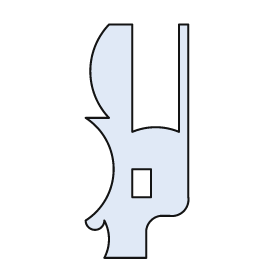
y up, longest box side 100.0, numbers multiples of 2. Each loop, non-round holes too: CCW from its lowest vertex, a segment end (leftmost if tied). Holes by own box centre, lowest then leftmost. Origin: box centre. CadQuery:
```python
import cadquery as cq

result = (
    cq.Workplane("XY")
    .moveTo(-14.0, -50.0)
    .lineTo(4.0, -50.0)
    .lineTo(4.0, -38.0)
    .threePointArc((6.0, -34.0), (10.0, -32.0))
    .lineTo(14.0, -32.0)
    .threePointArc((20.0, -30.0), (22.0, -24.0))
    .lineTo(22.0, 50.0)
    .lineTo(18.0, 50.0)
    .lineTo(18.0, 4.0)
    .threePointArc((8.0, 6.0), (-2.0, 4.0))
    .lineTo(-2.0, 50.0)
    .lineTo(-12.0, 50.0)
    .threePointArc((-20.0, 30.0), (-12.0, 10.0))
    .lineTo(-22.0, 10.0)
    .threePointArc((-10.0, -12.0), (-22.0, -34.0))
    .threePointArc((-18.0, -38.0), (-14.0, -34.0))
    .threePointArc((-12.0, -42.0), (-14.0, -50.0))
    .close()
    .moveTo(-2.0, -24.0)
    .lineTo(6.0, -24.0)
    .lineTo(6.0, -12.0)
    .lineTo(-2.0, -12.0)
    .close()
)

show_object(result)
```